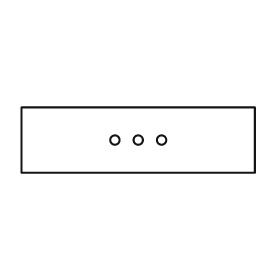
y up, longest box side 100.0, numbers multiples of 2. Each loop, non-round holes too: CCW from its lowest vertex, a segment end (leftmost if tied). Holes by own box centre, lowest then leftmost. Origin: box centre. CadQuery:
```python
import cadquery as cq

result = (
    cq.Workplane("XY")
    .moveTo(-50.0, -14.0)
    .lineTo(50.0, -14.0)
    .lineTo(50.0, 14.0)
    .lineTo(-50.0, 14.0)
    .close()
    .moveTo(-10.0, 0.0)
    .circle(2.0)
    .moveTo(0.0, 0.0)
    .circle(2.0)
    .moveTo(10.0, 0.0)
    .circle(2.0)
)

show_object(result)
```